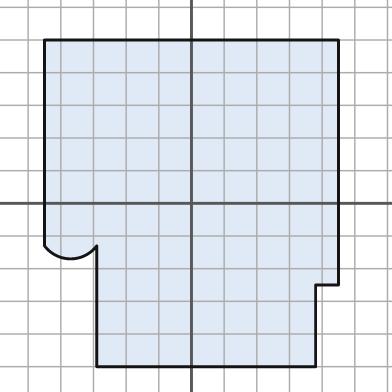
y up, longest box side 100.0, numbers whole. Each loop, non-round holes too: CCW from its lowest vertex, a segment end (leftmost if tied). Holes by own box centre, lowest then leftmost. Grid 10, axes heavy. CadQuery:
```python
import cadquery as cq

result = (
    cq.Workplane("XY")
    .moveTo(-29.0, -50.0)
    .lineTo(38.0, -50.0)
    .lineTo(38.0, -25.0)
    .lineTo(45.0, -25.0)
    .lineTo(45.0, 50.0)
    .lineTo(-45.0, 50.0)
    .lineTo(-45.0, -13.0)
    .threePointArc((-37.0, -17.0), (-29.0, -13.0))
    .close()
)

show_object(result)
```